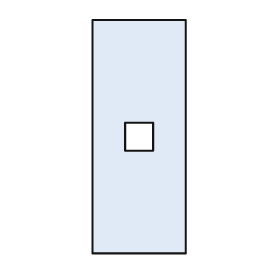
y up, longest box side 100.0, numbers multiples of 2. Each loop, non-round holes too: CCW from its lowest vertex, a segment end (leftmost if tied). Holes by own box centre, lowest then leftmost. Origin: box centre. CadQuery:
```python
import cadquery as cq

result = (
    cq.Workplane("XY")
    .moveTo(-20.0, -50.0)
    .lineTo(20.0, -50.0)
    .lineTo(20.0, 50.0)
    .lineTo(-20.0, 50.0)
    .close()
    .moveTo(-6.0, -6.0)
    .lineTo(6.0, -6.0)
    .lineTo(6.0, 6.0)
    .lineTo(-6.0, 6.0)
    .close()
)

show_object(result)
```